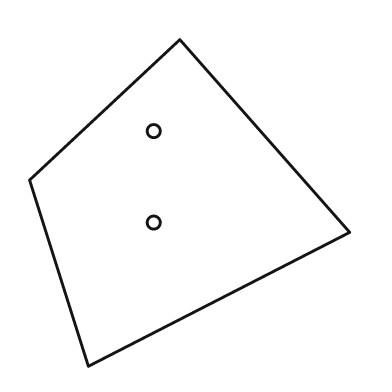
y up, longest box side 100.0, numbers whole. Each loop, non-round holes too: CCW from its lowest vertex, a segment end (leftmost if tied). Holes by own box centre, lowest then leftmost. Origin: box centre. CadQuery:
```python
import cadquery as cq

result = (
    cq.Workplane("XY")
    .moveTo(-31.0, -50.0)
    .lineTo(49.0, -9.0)
    .lineTo(-3.0, 50.0)
    .lineTo(-49.0, 7.0)
    .close()
    .moveTo(-11.0, -6.0)
    .circle(2.0)
    .moveTo(-11.0, 22.0)
    .circle(2.0)
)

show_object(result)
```